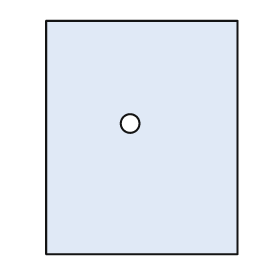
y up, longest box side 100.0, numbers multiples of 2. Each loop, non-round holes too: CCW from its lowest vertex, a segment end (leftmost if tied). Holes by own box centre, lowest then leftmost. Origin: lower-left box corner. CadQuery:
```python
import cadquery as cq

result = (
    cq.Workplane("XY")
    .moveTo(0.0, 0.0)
    .lineTo(82.0, 0.0)
    .lineTo(82.0, 100.0)
    .lineTo(0.0, 100.0)
    .close()
    .moveTo(36.0, 56.0)
    .circle(4.0)
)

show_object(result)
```